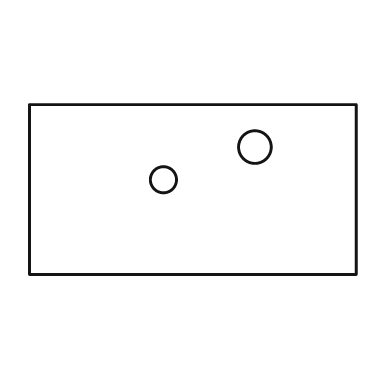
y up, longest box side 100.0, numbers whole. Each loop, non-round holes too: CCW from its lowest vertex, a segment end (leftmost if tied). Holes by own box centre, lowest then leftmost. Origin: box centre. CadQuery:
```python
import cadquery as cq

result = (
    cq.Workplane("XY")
    .moveTo(-50.0, -26.0)
    .lineTo(50.0, -26.0)
    .lineTo(50.0, 26.0)
    .lineTo(-50.0, 26.0)
    .close()
    .moveTo(-9.0, 3.0)
    .circle(4.0)
    .moveTo(19.0, 13.0)
    .circle(5.0)
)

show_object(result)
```